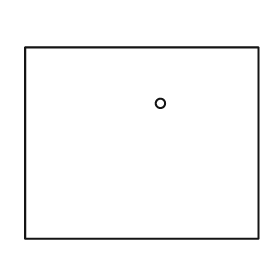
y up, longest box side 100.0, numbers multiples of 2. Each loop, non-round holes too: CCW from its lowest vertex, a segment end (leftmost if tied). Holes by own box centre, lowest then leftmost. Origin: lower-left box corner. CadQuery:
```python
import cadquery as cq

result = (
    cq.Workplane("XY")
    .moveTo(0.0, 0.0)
    .lineTo(100.0, 0.0)
    .lineTo(100.0, 82.0)
    .lineTo(0.0, 82.0)
    .close()
    .moveTo(58.0, 58.0)
    .circle(2.0)
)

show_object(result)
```